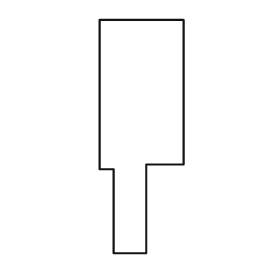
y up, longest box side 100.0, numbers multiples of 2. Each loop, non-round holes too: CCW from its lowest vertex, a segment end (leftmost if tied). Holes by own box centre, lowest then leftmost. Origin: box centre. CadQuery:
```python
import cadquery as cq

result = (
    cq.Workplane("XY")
    .moveTo(-12.0, -50.0)
    .lineTo(2.0, -50.0)
    .lineTo(2.0, -12.0)
    .lineTo(18.0, -12.0)
    .lineTo(18.0, 50.0)
    .lineTo(-18.0, 50.0)
    .lineTo(-18.0, -14.0)
    .lineTo(-12.0, -14.0)
    .close()
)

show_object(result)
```